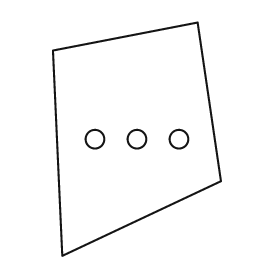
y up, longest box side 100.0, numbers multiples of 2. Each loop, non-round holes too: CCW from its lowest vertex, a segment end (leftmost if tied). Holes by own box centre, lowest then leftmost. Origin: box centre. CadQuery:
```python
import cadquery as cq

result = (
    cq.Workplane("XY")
    .moveTo(-32.0, -50.0)
    .lineTo(36.0, -18.0)
    .lineTo(26.0, 50.0)
    .lineTo(-36.0, 38.0)
    .close()
    .moveTo(-18.0, 0.0)
    .circle(4.0)
    .moveTo(0.0, 0.0)
    .circle(4.0)
    .moveTo(18.0, 0.0)
    .circle(4.0)
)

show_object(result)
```